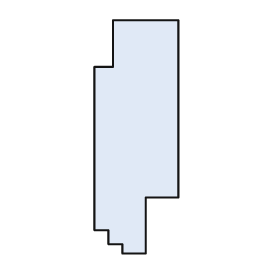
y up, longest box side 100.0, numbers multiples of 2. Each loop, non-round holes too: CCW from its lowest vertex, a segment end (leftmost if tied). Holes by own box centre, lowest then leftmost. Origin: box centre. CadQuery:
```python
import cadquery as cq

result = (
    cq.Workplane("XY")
    .moveTo(-6.0, -50.0)
    .lineTo(4.0, -50.0)
    .lineTo(4.0, -26.0)
    .lineTo(18.0, -26.0)
    .lineTo(18.0, 50.0)
    .lineTo(-10.0, 50.0)
    .lineTo(-10.0, 30.0)
    .lineTo(-18.0, 30.0)
    .lineTo(-18.0, -40.0)
    .lineTo(-12.0, -40.0)
    .lineTo(-12.0, -46.0)
    .lineTo(-6.0, -46.0)
    .close()
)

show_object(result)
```